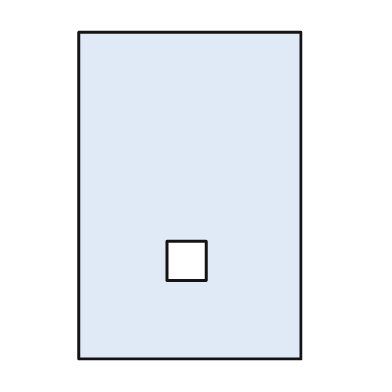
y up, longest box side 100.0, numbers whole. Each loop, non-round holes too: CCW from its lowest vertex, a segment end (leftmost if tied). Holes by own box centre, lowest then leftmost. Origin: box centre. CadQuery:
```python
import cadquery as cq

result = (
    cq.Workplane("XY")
    .moveTo(-34.0, -50.0)
    .lineTo(34.0, -50.0)
    .lineTo(34.0, 50.0)
    .lineTo(-34.0, 50.0)
    .close()
    .moveTo(-7.0, -26.0)
    .lineTo(5.0, -26.0)
    .lineTo(5.0, -14.0)
    .lineTo(-7.0, -14.0)
    .close()
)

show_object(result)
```